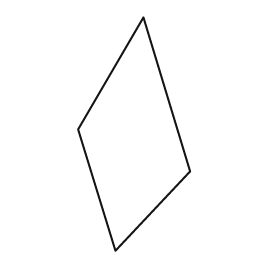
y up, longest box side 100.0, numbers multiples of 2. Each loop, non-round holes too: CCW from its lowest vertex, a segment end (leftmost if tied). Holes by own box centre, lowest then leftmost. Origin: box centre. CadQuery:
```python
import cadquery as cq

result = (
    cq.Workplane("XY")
    .moveTo(-8.0, -50.0)
    .lineTo(24.0, -16.0)
    .lineTo(4.0, 50.0)
    .lineTo(-24.0, 2.0)
    .close()
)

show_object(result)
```